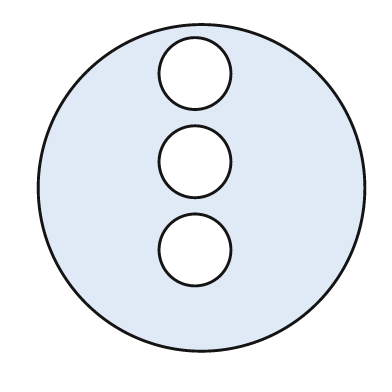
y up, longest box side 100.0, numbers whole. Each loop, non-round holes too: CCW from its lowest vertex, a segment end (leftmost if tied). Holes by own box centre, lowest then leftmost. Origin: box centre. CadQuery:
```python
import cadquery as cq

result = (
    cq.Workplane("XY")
    .moveTo(0.0, 0.0)
    .circle(50.0)
    .moveTo(-2.0, -19.0)
    .circle(11.0)
    .moveTo(-2.0, 8.0)
    .circle(11.0)
    .moveTo(-2.0, 35.0)
    .circle(11.0)
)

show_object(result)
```